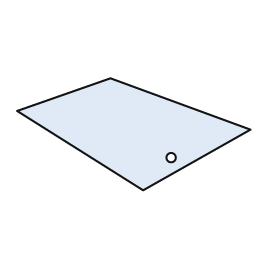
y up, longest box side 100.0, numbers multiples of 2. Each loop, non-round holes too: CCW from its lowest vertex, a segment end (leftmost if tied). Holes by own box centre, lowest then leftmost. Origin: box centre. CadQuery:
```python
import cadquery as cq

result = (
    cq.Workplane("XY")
    .moveTo(4.0, -24.0)
    .lineTo(50.0, 2.0)
    .lineTo(-10.0, 24.0)
    .lineTo(-50.0, 10.0)
    .close()
    .moveTo(16.0, -10.0)
    .circle(2.0)
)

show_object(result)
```